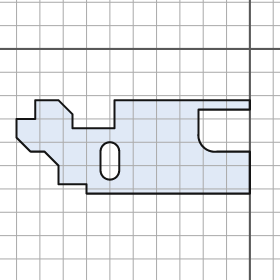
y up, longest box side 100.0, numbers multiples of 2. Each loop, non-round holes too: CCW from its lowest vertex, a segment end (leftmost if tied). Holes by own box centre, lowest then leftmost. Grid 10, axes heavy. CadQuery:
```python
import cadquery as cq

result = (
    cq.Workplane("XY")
    .moveTo(-70.0, -62.0)
    .lineTo(0.0, -62.0)
    .lineTo(0.0, -44.0)
    .lineTo(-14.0, -44.0)
    .threePointArc((-20.0, -42.0), (-22.0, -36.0))
    .lineTo(-22.0, -26.0)
    .lineTo(0.0, -26.0)
    .lineTo(0.0, -22.0)
    .lineTo(-58.0, -22.0)
    .lineTo(-58.0, -34.0)
    .lineTo(-76.0, -34.0)
    .lineTo(-76.0, -28.0)
    .lineTo(-82.0, -22.0)
    .lineTo(-92.0, -22.0)
    .lineTo(-92.0, -30.0)
    .lineTo(-100.0, -30.0)
    .lineTo(-100.0, -38.0)
    .lineTo(-94.0, -44.0)
    .lineTo(-88.0, -44.0)
    .lineTo(-82.0, -50.0)
    .lineTo(-82.0, -58.0)
    .lineTo(-70.0, -58.0)
    .close()
    .moveTo(-64.0, -52.0)
    .threePointArc((-60.0, -56.0), (-56.0, -52.0))
    .lineTo(-56.0, -44.0)
    .threePointArc((-60.0, -40.0), (-64.0, -44.0))
    .close()
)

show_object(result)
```